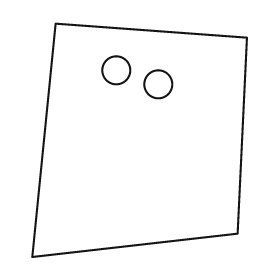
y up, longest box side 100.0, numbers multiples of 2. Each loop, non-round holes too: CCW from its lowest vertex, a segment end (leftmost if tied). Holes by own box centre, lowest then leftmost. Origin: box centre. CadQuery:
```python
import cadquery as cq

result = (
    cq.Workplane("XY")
    .moveTo(-46.0, -50.0)
    .lineTo(42.0, -40.0)
    .lineTo(46.0, 44.0)
    .lineTo(-36.0, 50.0)
    .close()
    .moveTo(8.0, 24.0)
    .circle(6.0)
    .moveTo(-10.0, 30.0)
    .circle(6.0)
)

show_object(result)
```